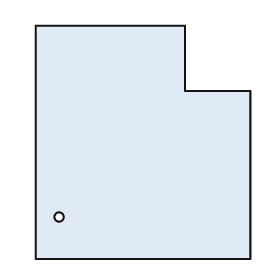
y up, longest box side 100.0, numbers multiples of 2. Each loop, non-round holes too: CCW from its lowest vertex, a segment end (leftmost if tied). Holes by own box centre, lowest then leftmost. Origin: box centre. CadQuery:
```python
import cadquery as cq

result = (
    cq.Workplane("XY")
    .moveTo(-46.0, -50.0)
    .lineTo(46.0, -50.0)
    .lineTo(46.0, 22.0)
    .lineTo(18.0, 22.0)
    .lineTo(18.0, 50.0)
    .lineTo(-46.0, 50.0)
    .close()
    .moveTo(-36.0, -32.0)
    .circle(2.0)
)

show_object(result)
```